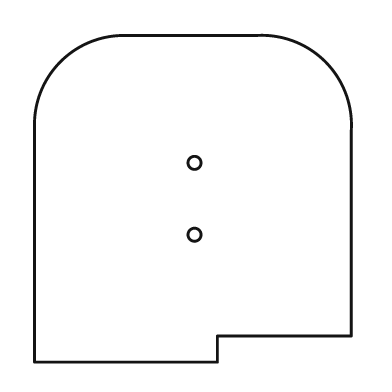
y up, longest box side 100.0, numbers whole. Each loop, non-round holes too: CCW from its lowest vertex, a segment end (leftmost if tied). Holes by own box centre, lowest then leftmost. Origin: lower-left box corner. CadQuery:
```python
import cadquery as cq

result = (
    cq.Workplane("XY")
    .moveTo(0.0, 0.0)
    .lineTo(56.0, 0.0)
    .lineTo(56.0, 8.0)
    .lineTo(97.0, 8.0)
    .lineTo(97.0, 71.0)
    .threePointArc((89.0, 92.0), (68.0, 100.0))
    .lineTo(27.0, 100.0)
    .threePointArc((8.0, 92.0), (0.0, 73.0))
    .close()
    .moveTo(49.0, 39.0)
    .circle(2.0)
    .moveTo(49.0, 61.0)
    .circle(2.0)
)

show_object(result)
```